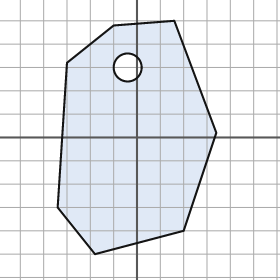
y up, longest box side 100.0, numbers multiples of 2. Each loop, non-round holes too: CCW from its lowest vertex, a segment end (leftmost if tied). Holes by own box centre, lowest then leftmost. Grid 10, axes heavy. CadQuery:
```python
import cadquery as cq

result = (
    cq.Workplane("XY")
    .moveTo(-18.0, -50.0)
    .lineTo(20.0, -40.0)
    .lineTo(34.0, 2.0)
    .lineTo(16.0, 50.0)
    .lineTo(-10.0, 48.0)
    .lineTo(-30.0, 32.0)
    .lineTo(-34.0, -30.0)
    .close()
    .moveTo(-4.0, 30.0)
    .circle(6.0)
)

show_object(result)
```